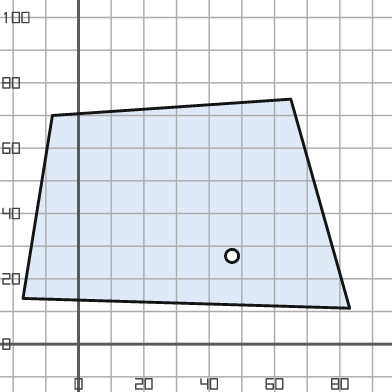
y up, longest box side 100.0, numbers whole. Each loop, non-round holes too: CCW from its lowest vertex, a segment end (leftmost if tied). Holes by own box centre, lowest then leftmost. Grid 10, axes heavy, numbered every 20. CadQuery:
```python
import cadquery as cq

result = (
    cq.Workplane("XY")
    .moveTo(83.0, 11.0)
    .lineTo(65.0, 75.0)
    .lineTo(-8.0, 70.0)
    .lineTo(-17.0, 14.0)
    .close()
    .moveTo(47.0, 27.0)
    .circle(2.0)
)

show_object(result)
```